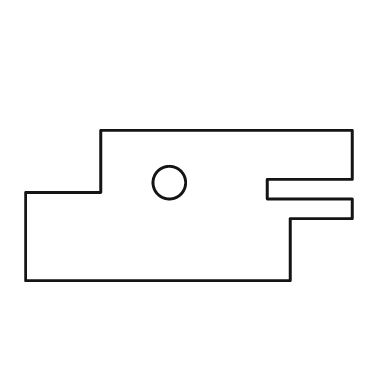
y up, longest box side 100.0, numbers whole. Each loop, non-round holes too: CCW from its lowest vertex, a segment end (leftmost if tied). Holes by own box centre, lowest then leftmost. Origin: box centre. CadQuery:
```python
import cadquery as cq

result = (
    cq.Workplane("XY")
    .moveTo(-50.0, -23.0)
    .lineTo(31.0, -23.0)
    .lineTo(31.0, -4.0)
    .lineTo(50.0, -4.0)
    .lineTo(50.0, 2.0)
    .lineTo(24.0, 2.0)
    .lineTo(24.0, 8.0)
    .lineTo(50.0, 8.0)
    .lineTo(50.0, 23.0)
    .lineTo(-27.0, 23.0)
    .lineTo(-27.0, 4.0)
    .lineTo(-50.0, 4.0)
    .close()
    .moveTo(-6.0, 7.0)
    .circle(5.0)
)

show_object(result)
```